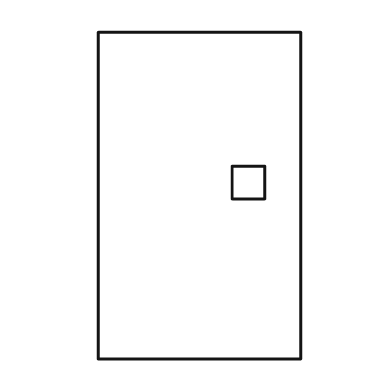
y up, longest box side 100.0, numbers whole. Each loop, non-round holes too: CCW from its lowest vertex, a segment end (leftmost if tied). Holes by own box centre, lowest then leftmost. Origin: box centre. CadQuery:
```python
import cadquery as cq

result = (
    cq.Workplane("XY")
    .moveTo(-31.0, -50.0)
    .lineTo(31.0, -50.0)
    .lineTo(31.0, 50.0)
    .lineTo(-31.0, 50.0)
    .close()
    .moveTo(10.0, -1.0)
    .lineTo(20.0, -1.0)
    .lineTo(20.0, 9.0)
    .lineTo(10.0, 9.0)
    .close()
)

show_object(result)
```